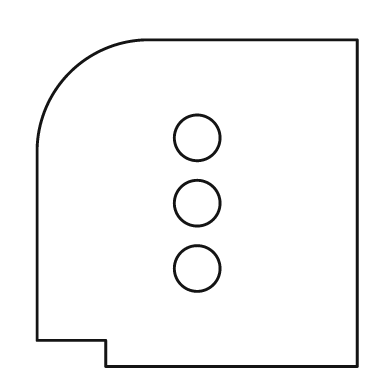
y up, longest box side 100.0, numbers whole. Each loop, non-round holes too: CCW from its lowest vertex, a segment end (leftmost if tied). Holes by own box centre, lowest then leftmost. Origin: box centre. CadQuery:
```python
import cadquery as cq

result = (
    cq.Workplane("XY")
    .moveTo(-28.0, -50.0)
    .lineTo(49.0, -50.0)
    .lineTo(49.0, 50.0)
    .lineTo(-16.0, 50.0)
    .threePointArc((-39.0, 40.0), (-49.0, 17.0))
    .lineTo(-49.0, -42.0)
    .lineTo(-28.0, -42.0)
    .close()
    .moveTo(0.0, -20.0)
    .circle(7.0)
    .moveTo(0.0, 0.0)
    .circle(7.0)
    .moveTo(0.0, 20.0)
    .circle(7.0)
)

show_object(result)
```